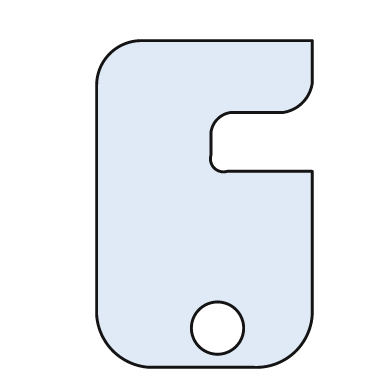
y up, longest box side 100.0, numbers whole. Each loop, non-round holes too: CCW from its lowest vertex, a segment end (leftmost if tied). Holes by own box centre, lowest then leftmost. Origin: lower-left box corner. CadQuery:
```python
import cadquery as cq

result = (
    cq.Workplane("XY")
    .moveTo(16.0, 0.0)
    .lineTo(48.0, 0.0)
    .threePointArc((61.0, 5.0), (66.0, 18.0))
    .lineTo(66.0, 60.0)
    .lineTo(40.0, 60.0)
    .threePointArc((36.0, 61.0), (35.0, 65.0))
    .lineTo(35.0, 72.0)
    .threePointArc((37.0, 76.0), (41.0, 78.0))
    .lineTo(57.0, 78.0)
    .threePointArc((63.0, 81.0), (66.0, 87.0))
    .lineTo(66.0, 100.0)
    .lineTo(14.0, 100.0)
    .threePointArc((4.0, 96.0), (0.0, 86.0))
    .lineTo(0.0, 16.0)
    .threePointArc((5.0, 5.0), (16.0, 0.0))
    .close()
    .moveTo(37.0, 12.0)
    .circle(8.0)
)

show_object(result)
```